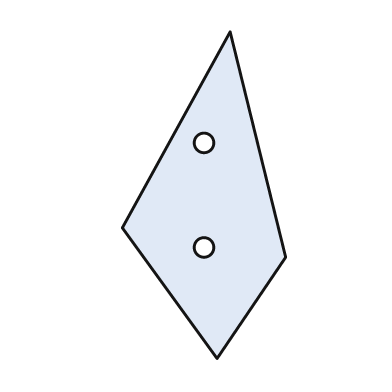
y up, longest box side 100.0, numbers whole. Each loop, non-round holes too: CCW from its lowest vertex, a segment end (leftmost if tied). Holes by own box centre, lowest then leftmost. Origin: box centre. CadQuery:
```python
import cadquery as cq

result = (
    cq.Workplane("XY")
    .moveTo(4.0, -50.0)
    .lineTo(25.0, -19.0)
    .lineTo(8.0, 50.0)
    .lineTo(-25.0, -10.0)
    .close()
    .moveTo(0.0, -16.0)
    .circle(3.0)
    .moveTo(0.0, 16.0)
    .circle(3.0)
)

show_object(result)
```